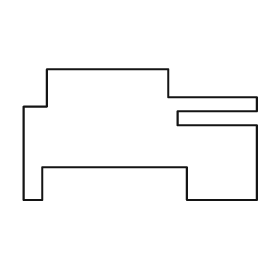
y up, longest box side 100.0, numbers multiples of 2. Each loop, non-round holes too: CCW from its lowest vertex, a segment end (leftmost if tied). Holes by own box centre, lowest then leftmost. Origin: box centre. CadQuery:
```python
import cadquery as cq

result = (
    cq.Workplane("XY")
    .moveTo(-50.0, -28.0)
    .lineTo(-42.0, -28.0)
    .lineTo(-42.0, -14.0)
    .lineTo(20.0, -14.0)
    .lineTo(20.0, -28.0)
    .lineTo(50.0, -28.0)
    .lineTo(50.0, 4.0)
    .lineTo(16.0, 4.0)
    .lineTo(16.0, 10.0)
    .lineTo(50.0, 10.0)
    .lineTo(50.0, 16.0)
    .lineTo(12.0, 16.0)
    .lineTo(12.0, 28.0)
    .lineTo(-40.0, 28.0)
    .lineTo(-40.0, 12.0)
    .lineTo(-50.0, 12.0)
    .close()
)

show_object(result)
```